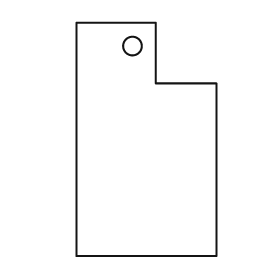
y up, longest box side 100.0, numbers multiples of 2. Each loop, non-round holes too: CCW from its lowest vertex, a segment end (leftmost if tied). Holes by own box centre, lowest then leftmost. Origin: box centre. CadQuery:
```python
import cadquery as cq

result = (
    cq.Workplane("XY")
    .moveTo(-30.0, -50.0)
    .lineTo(30.0, -50.0)
    .lineTo(30.0, 24.0)
    .lineTo(4.0, 24.0)
    .lineTo(4.0, 50.0)
    .lineTo(-30.0, 50.0)
    .close()
    .moveTo(-6.0, 40.0)
    .circle(4.0)
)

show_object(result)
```